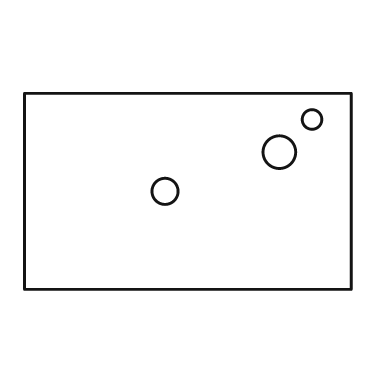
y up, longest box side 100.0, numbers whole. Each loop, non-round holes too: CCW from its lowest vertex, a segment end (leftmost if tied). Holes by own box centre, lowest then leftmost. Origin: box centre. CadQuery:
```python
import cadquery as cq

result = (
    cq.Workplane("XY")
    .moveTo(-50.0, -30.0)
    .lineTo(50.0, -30.0)
    .lineTo(50.0, 30.0)
    .lineTo(-50.0, 30.0)
    .close()
    .moveTo(-7.0, 0.0)
    .circle(4.0)
    .moveTo(28.0, 12.0)
    .circle(5.0)
    .moveTo(38.0, 22.0)
    .circle(3.0)
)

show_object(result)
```